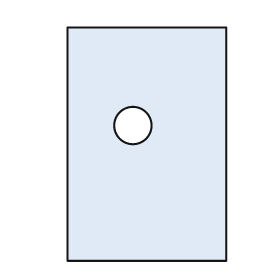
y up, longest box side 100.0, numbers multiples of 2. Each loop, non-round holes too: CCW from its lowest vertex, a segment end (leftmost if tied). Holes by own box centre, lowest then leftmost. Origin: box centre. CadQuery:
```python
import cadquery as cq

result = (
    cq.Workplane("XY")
    .moveTo(-34.0, -50.0)
    .lineTo(34.0, -50.0)
    .lineTo(34.0, 50.0)
    .lineTo(-34.0, 50.0)
    .close()
    .moveTo(-6.0, 8.0)
    .circle(8.0)
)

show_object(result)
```